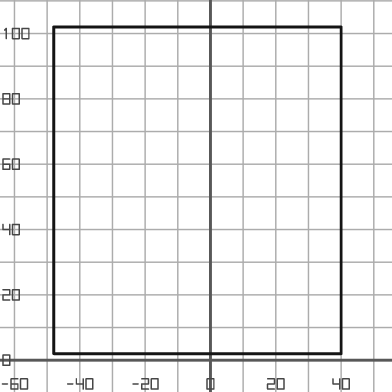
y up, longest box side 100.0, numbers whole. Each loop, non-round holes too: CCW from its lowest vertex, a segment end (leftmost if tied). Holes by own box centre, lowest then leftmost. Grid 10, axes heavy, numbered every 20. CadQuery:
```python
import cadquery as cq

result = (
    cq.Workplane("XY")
    .moveTo(-48.0, 2.0)
    .lineTo(40.0, 2.0)
    .lineTo(40.0, 102.0)
    .lineTo(-48.0, 102.0)
    .close()
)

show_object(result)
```